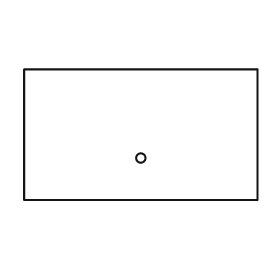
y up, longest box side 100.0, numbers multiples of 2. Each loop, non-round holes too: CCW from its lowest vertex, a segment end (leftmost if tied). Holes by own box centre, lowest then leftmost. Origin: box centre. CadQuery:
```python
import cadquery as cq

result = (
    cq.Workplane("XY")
    .moveTo(-50.0, -28.0)
    .lineTo(50.0, -28.0)
    .lineTo(50.0, 28.0)
    .lineTo(-50.0, 28.0)
    .close()
    .moveTo(0.0, -10.0)
    .circle(2.0)
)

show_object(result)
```